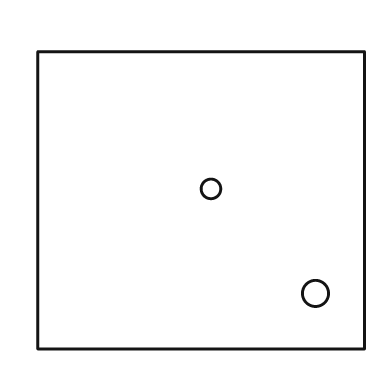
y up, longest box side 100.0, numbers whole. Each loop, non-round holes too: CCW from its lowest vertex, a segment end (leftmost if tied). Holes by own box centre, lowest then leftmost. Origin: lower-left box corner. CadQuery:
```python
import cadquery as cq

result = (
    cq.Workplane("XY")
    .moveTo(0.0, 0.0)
    .lineTo(100.0, 0.0)
    .lineTo(100.0, 91.0)
    .lineTo(0.0, 91.0)
    .close()
    .moveTo(85.0, 17.0)
    .circle(4.0)
    .moveTo(53.0, 49.0)
    .circle(3.0)
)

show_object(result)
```